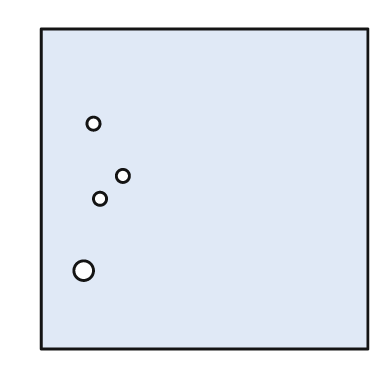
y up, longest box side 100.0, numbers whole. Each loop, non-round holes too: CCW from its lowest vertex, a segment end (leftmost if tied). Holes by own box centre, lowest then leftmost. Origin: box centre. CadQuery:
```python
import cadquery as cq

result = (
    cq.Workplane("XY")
    .moveTo(-50.0, -49.0)
    .lineTo(50.0, -49.0)
    .lineTo(50.0, 49.0)
    .lineTo(-50.0, 49.0)
    .close()
    .moveTo(-37.0, -25.0)
    .circle(3.0)
    .moveTo(-32.0, -3.0)
    .circle(2.0)
    .moveTo(-25.0, 4.0)
    .circle(2.0)
    .moveTo(-34.0, 20.0)
    .circle(2.0)
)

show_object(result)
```